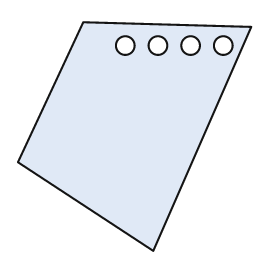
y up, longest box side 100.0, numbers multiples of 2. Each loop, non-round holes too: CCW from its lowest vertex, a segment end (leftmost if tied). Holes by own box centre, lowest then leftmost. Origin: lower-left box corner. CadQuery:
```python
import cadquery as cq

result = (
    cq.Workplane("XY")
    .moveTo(58.0, 0.0)
    .lineTo(100.0, 96.0)
    .lineTo(28.0, 98.0)
    .lineTo(0.0, 38.0)
    .close()
    .moveTo(46.0, 88.0)
    .circle(4.0)
    .moveTo(60.0, 88.0)
    .circle(4.0)
    .moveTo(74.0, 88.0)
    .circle(4.0)
    .moveTo(88.0, 88.0)
    .circle(4.0)
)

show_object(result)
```